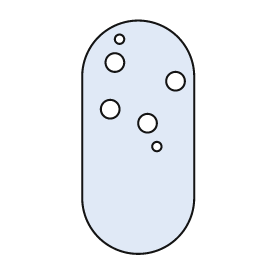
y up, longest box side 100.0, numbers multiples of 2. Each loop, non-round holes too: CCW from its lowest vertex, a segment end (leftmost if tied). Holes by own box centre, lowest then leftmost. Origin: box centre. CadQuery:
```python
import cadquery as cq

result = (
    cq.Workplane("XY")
    .moveTo(-24.0, -26.0)
    .threePointArc((0.0, -50.0), (24.0, -26.0))
    .lineTo(24.0, 26.0)
    .threePointArc((0.0, 50.0), (-24.0, 26.0))
    .close()
    .moveTo(8.0, -4.0)
    .circle(2.0)
    .moveTo(4.0, 6.0)
    .circle(4.0)
    .moveTo(-12.0, 12.0)
    .circle(4.0)
    .moveTo(16.0, 24.0)
    .circle(4.0)
    .moveTo(-10.0, 32.0)
    .circle(4.0)
    .moveTo(-8.0, 42.0)
    .circle(2.0)
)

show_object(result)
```